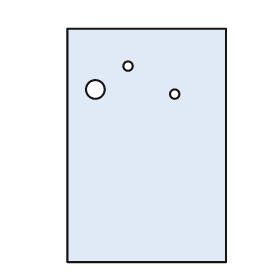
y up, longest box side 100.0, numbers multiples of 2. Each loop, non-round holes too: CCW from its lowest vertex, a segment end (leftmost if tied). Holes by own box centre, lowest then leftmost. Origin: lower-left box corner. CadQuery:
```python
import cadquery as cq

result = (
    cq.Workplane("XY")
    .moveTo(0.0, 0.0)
    .lineTo(68.0, 0.0)
    .lineTo(68.0, 100.0)
    .lineTo(0.0, 100.0)
    .close()
    .moveTo(46.0, 72.0)
    .circle(2.0)
    .moveTo(12.0, 74.0)
    .circle(4.0)
    .moveTo(26.0, 84.0)
    .circle(2.0)
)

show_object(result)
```